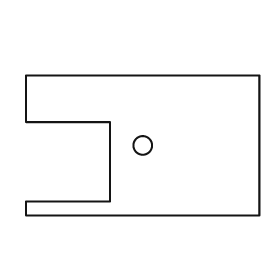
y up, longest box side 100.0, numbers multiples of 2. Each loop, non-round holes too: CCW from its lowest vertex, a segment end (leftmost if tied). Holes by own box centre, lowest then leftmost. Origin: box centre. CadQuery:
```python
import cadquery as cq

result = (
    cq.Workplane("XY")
    .moveTo(-50.0, -30.0)
    .lineTo(50.0, -30.0)
    .lineTo(50.0, 30.0)
    .lineTo(-50.0, 30.0)
    .lineTo(-50.0, 10.0)
    .lineTo(-14.0, 10.0)
    .lineTo(-14.0, -24.0)
    .lineTo(-50.0, -24.0)
    .close()
    .moveTo(0.0, 0.0)
    .circle(4.0)
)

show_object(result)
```